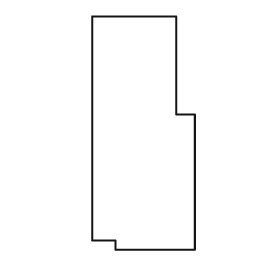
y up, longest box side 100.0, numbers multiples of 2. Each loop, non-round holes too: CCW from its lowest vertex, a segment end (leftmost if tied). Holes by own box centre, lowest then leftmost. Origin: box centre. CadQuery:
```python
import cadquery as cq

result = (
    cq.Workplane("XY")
    .moveTo(-12.0, -50.0)
    .lineTo(22.0, -50.0)
    .lineTo(22.0, 8.0)
    .lineTo(14.0, 8.0)
    .lineTo(14.0, 50.0)
    .lineTo(-22.0, 50.0)
    .lineTo(-22.0, -46.0)
    .lineTo(-12.0, -46.0)
    .close()
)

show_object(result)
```